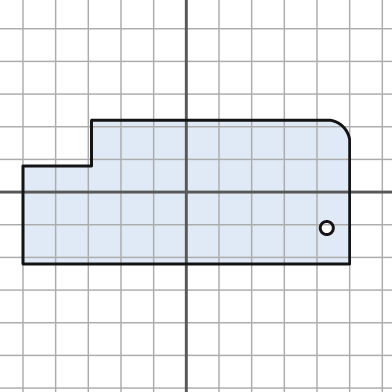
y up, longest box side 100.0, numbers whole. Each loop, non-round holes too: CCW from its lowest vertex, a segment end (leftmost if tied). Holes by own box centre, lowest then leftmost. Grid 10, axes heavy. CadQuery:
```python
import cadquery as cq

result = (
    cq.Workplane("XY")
    .moveTo(-50.0, -22.0)
    .lineTo(50.0, -22.0)
    .lineTo(50.0, 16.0)
    .threePointArc((48.0, 20.0), (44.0, 22.0))
    .lineTo(-29.0, 22.0)
    .lineTo(-29.0, 8.0)
    .lineTo(-50.0, 8.0)
    .close()
    .moveTo(43.0, -11.0)
    .circle(2.0)
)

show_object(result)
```